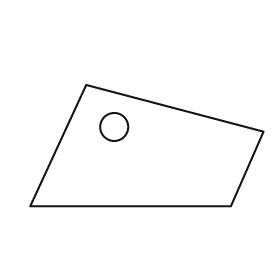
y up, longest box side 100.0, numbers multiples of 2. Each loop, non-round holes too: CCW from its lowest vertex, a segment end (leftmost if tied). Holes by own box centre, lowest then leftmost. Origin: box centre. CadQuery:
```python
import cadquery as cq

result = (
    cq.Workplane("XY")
    .moveTo(-50.0, -26.0)
    .lineTo(36.0, -26.0)
    .lineTo(50.0, 6.0)
    .lineTo(-26.0, 26.0)
    .close()
    .moveTo(-14.0, 8.0)
    .circle(6.0)
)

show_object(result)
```